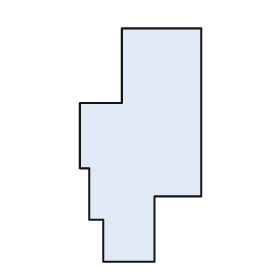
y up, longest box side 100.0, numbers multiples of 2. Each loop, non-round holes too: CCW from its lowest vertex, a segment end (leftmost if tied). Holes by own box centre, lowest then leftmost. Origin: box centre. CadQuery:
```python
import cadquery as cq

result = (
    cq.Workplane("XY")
    .moveTo(-16.0, -50.0)
    .lineTo(6.0, -50.0)
    .lineTo(6.0, -22.0)
    .lineTo(26.0, -22.0)
    .lineTo(26.0, 50.0)
    .lineTo(-8.0, 50.0)
    .lineTo(-8.0, 18.0)
    .lineTo(-26.0, 18.0)
    .lineTo(-26.0, -10.0)
    .lineTo(-22.0, -10.0)
    .lineTo(-22.0, -32.0)
    .lineTo(-16.0, -32.0)
    .close()
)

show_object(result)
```